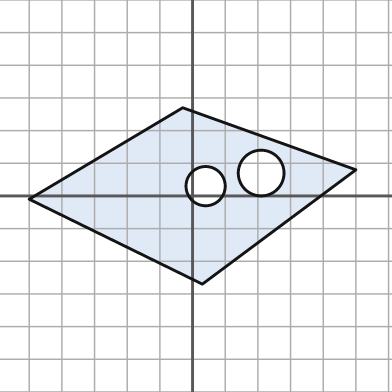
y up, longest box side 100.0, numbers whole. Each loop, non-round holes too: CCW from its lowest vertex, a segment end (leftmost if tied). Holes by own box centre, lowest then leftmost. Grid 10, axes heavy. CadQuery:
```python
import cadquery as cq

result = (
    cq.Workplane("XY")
    .moveTo(3.0, -27.0)
    .lineTo(50.0, 8.0)
    .lineTo(-3.0, 27.0)
    .lineTo(-50.0, -1.0)
    .close()
    .moveTo(4.0, 3.0)
    .circle(6.0)
    .moveTo(21.0, 7.0)
    .circle(7.0)
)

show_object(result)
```